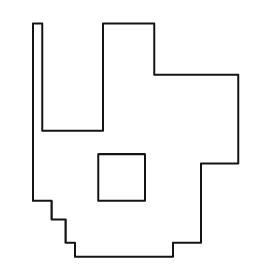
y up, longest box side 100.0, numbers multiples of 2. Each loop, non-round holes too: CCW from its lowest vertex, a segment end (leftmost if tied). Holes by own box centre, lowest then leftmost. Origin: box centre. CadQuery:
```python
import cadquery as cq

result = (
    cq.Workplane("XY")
    .moveTo(-26.0, -50.0)
    .lineTo(16.0, -50.0)
    .lineTo(16.0, -44.0)
    .lineTo(28.0, -44.0)
    .lineTo(28.0, -10.0)
    .lineTo(44.0, -10.0)
    .lineTo(44.0, 28.0)
    .lineTo(8.0, 28.0)
    .lineTo(8.0, 50.0)
    .lineTo(-14.0, 50.0)
    .lineTo(-14.0, 4.0)
    .lineTo(-40.0, 4.0)
    .lineTo(-40.0, 50.0)
    .lineTo(-44.0, 50.0)
    .lineTo(-44.0, -26.0)
    .lineTo(-36.0, -26.0)
    .lineTo(-36.0, -34.0)
    .lineTo(-30.0, -34.0)
    .lineTo(-30.0, -44.0)
    .lineTo(-26.0, -44.0)
    .close()
    .moveTo(-16.0, -26.0)
    .lineTo(4.0, -26.0)
    .lineTo(4.0, -6.0)
    .lineTo(-16.0, -6.0)
    .close()
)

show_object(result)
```